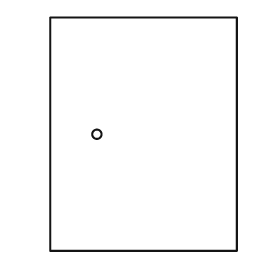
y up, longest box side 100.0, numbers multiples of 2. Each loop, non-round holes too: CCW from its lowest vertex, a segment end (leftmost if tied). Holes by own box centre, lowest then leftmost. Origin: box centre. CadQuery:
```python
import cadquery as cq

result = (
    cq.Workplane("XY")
    .moveTo(-40.0, -50.0)
    .lineTo(40.0, -50.0)
    .lineTo(40.0, 50.0)
    .lineTo(-40.0, 50.0)
    .close()
    .moveTo(-20.0, 0.0)
    .circle(2.0)
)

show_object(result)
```